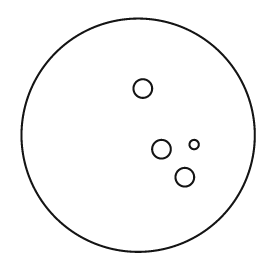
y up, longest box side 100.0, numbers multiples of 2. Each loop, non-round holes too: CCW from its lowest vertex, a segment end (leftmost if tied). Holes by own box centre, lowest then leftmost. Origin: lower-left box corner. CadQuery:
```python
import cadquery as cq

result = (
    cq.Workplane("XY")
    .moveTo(50.0, 50.0)
    .circle(50.0)
    .moveTo(70.0, 32.0)
    .circle(4.0)
    .moveTo(60.0, 44.0)
    .circle(4.0)
    .moveTo(74.0, 46.0)
    .circle(2.0)
    .moveTo(52.0, 70.0)
    .circle(4.0)
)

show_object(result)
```